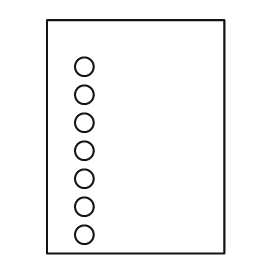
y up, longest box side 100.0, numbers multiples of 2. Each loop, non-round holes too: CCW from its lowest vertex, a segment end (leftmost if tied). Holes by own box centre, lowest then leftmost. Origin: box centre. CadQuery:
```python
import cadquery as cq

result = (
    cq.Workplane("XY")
    .moveTo(-38.0, -50.0)
    .lineTo(38.0, -50.0)
    .lineTo(38.0, 50.0)
    .lineTo(-38.0, 50.0)
    .close()
    .moveTo(-22.0, -42.0)
    .circle(4.0)
    .moveTo(-22.0, -30.0)
    .circle(4.0)
    .moveTo(-22.0, -18.0)
    .circle(4.0)
    .moveTo(-22.0, -6.0)
    .circle(4.0)
    .moveTo(-22.0, 6.0)
    .circle(4.0)
    .moveTo(-22.0, 18.0)
    .circle(4.0)
    .moveTo(-22.0, 30.0)
    .circle(4.0)
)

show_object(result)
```